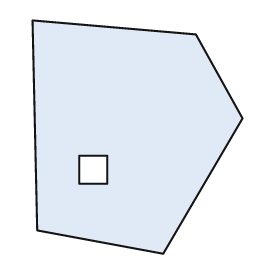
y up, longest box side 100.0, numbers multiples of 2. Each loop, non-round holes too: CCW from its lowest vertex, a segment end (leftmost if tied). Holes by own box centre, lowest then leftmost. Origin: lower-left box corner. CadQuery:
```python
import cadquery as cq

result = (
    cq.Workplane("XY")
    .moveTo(56.0, 0.0)
    .lineTo(90.0, 58.0)
    .lineTo(70.0, 94.0)
    .lineTo(0.0, 100.0)
    .lineTo(2.0, 10.0)
    .close()
    .moveTo(20.0, 30.0)
    .lineTo(32.0, 30.0)
    .lineTo(32.0, 42.0)
    .lineTo(20.0, 42.0)
    .close()
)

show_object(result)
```